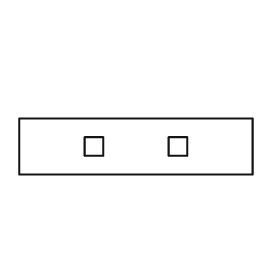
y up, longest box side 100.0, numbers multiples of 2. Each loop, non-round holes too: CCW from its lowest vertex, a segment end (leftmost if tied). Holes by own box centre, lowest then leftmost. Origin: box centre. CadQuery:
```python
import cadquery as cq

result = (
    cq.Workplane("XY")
    .moveTo(-50.0, -12.0)
    .lineTo(50.0, -12.0)
    .lineTo(50.0, 12.0)
    .lineTo(-50.0, 12.0)
    .close()
    .moveTo(-22.0, -4.0)
    .lineTo(-14.0, -4.0)
    .lineTo(-14.0, 4.0)
    .lineTo(-22.0, 4.0)
    .close()
    .moveTo(14.0, -4.0)
    .lineTo(22.0, -4.0)
    .lineTo(22.0, 4.0)
    .lineTo(14.0, 4.0)
    .close()
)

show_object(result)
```